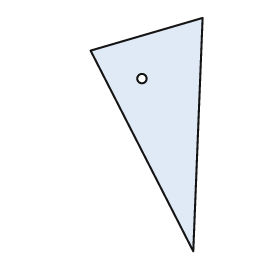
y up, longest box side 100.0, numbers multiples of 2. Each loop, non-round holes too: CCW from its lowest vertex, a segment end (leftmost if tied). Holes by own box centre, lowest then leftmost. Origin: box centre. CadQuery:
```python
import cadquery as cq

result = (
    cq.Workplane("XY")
    .moveTo(20.0, -50.0)
    .lineTo(24.0, 50.0)
    .lineTo(-24.0, 36.0)
    .close()
    .moveTo(-2.0, 24.0)
    .circle(2.0)
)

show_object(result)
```